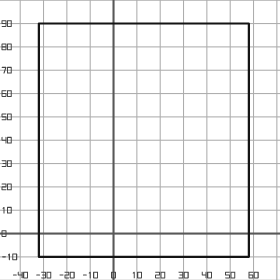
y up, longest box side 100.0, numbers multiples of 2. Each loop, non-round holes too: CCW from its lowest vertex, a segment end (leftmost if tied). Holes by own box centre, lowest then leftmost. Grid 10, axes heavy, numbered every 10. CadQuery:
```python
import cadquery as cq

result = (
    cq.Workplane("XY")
    .moveTo(-32.0, -10.0)
    .lineTo(58.0, -10.0)
    .lineTo(58.0, 90.0)
    .lineTo(-32.0, 90.0)
    .close()
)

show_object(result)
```